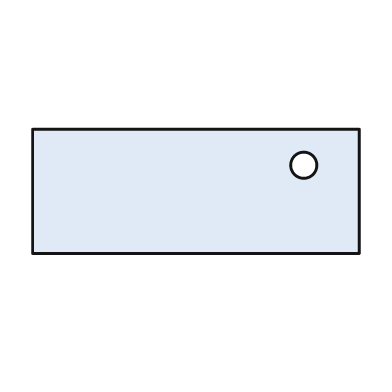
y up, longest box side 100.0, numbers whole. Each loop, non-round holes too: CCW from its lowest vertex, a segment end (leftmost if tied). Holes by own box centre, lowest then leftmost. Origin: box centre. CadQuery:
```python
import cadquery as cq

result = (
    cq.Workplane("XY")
    .moveTo(-50.0, -19.0)
    .lineTo(50.0, -19.0)
    .lineTo(50.0, 19.0)
    .lineTo(-50.0, 19.0)
    .close()
    .moveTo(33.0, 8.0)
    .circle(4.0)
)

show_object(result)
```